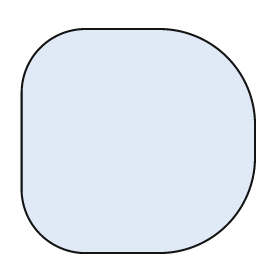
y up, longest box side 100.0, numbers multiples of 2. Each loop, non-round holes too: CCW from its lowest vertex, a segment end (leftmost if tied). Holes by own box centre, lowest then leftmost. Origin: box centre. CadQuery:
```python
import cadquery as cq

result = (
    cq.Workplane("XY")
    .moveTo(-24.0, -48.0)
    .lineTo(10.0, -48.0)
    .threePointArc((38.0, -36.0), (50.0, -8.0))
    .lineTo(50.0, 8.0)
    .threePointArc((38.0, 36.0), (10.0, 48.0))
    .lineTo(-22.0, 48.0)
    .threePointArc((-42.0, 40.0), (-50.0, 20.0))
    .lineTo(-50.0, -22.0)
    .threePointArc((-42.0, -40.0), (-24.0, -48.0))
    .close()
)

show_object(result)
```